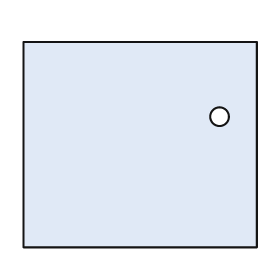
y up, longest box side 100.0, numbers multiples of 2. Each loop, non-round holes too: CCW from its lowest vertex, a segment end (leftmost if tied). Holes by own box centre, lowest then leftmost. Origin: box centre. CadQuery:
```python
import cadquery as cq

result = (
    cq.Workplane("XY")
    .moveTo(-50.0, -44.0)
    .lineTo(50.0, -44.0)
    .lineTo(50.0, 44.0)
    .lineTo(-50.0, 44.0)
    .close()
    .moveTo(34.0, 12.0)
    .circle(4.0)
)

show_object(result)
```